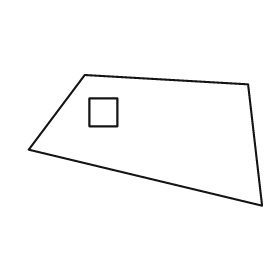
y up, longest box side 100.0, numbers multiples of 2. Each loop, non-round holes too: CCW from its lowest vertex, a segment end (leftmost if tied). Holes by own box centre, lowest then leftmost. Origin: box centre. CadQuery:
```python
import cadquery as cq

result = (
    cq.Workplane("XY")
    .moveTo(50.0, -28.0)
    .lineTo(44.0, 24.0)
    .lineTo(-26.0, 28.0)
    .lineTo(-50.0, -4.0)
    .close()
    .moveTo(-24.0, 6.0)
    .lineTo(-12.0, 6.0)
    .lineTo(-12.0, 18.0)
    .lineTo(-24.0, 18.0)
    .close()
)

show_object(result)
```